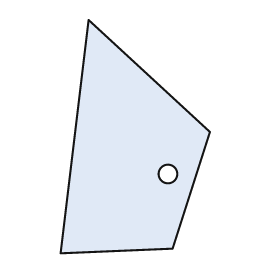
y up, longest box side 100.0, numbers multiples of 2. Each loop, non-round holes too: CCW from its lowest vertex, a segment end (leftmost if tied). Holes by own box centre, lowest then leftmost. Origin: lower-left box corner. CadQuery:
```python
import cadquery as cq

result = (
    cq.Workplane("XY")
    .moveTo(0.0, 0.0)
    .lineTo(48.0, 2.0)
    .lineTo(64.0, 52.0)
    .lineTo(12.0, 100.0)
    .close()
    .moveTo(46.0, 34.0)
    .circle(4.0)
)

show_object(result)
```